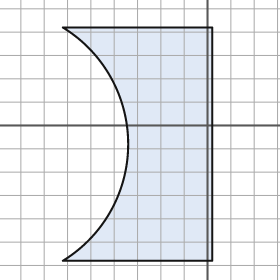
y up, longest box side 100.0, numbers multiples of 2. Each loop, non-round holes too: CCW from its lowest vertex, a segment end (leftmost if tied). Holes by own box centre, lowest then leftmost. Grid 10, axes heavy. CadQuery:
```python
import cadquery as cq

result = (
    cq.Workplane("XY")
    .moveTo(-62.0, -58.0)
    .lineTo(2.0, -58.0)
    .lineTo(2.0, 42.0)
    .lineTo(-62.0, 42.0)
    .threePointArc((-34.0, -8.0), (-62.0, -58.0))
    .close()
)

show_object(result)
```